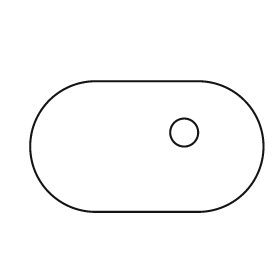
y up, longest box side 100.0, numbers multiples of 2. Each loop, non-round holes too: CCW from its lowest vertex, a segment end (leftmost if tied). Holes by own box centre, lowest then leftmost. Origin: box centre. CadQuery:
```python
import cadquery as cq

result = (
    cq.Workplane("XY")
    .moveTo(-22.0, -28.0)
    .lineTo(22.0, -28.0)
    .threePointArc((50.0, 0.0), (22.0, 28.0))
    .lineTo(-22.0, 28.0)
    .threePointArc((-50.0, 0.0), (-22.0, -28.0))
    .close()
    .moveTo(16.0, 6.0)
    .circle(6.0)
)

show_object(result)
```